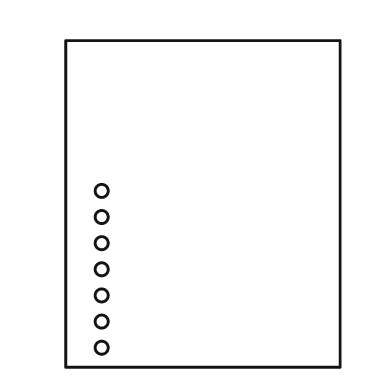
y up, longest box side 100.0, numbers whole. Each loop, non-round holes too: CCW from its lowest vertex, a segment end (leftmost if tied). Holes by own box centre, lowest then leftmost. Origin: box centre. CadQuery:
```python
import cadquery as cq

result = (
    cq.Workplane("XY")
    .moveTo(-42.0, -50.0)
    .lineTo(42.0, -50.0)
    .lineTo(42.0, 50.0)
    .lineTo(-42.0, 50.0)
    .close()
    .moveTo(-31.0, -44.0)
    .circle(2.0)
    .moveTo(-31.0, -36.0)
    .circle(2.0)
    .moveTo(-31.0, -28.0)
    .circle(2.0)
    .moveTo(-31.0, -20.0)
    .circle(2.0)
    .moveTo(-31.0, -12.0)
    .circle(2.0)
    .moveTo(-31.0, -4.0)
    .circle(2.0)
    .moveTo(-31.0, 4.0)
    .circle(2.0)
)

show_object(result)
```